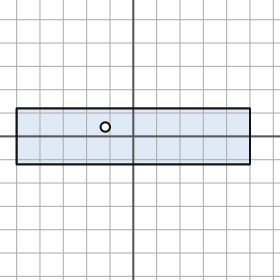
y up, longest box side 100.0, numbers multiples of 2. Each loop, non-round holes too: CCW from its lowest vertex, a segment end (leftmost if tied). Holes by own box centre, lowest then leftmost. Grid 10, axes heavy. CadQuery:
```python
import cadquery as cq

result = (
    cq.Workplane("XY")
    .moveTo(-50.0, -12.0)
    .lineTo(50.0, -12.0)
    .lineTo(50.0, 12.0)
    .lineTo(-50.0, 12.0)
    .close()
    .moveTo(-12.0, 4.0)
    .circle(2.0)
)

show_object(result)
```